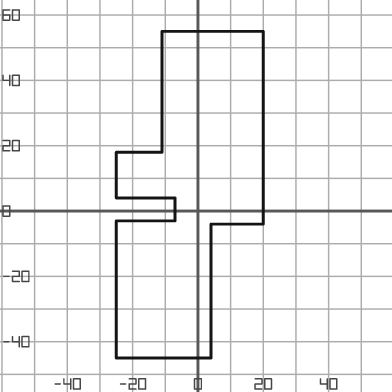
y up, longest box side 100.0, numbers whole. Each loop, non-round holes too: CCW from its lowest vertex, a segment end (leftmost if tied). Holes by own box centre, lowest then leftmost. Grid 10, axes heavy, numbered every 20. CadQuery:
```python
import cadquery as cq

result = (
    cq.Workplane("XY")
    .moveTo(-25.0, -45.0)
    .lineTo(4.0, -45.0)
    .lineTo(4.0, -4.0)
    .lineTo(20.0, -4.0)
    .lineTo(20.0, 55.0)
    .lineTo(-11.0, 55.0)
    .lineTo(-11.0, 18.0)
    .lineTo(-25.0, 18.0)
    .lineTo(-25.0, 4.0)
    .lineTo(-7.0, 4.0)
    .lineTo(-7.0, -3.0)
    .lineTo(-25.0, -3.0)
    .close()
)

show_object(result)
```